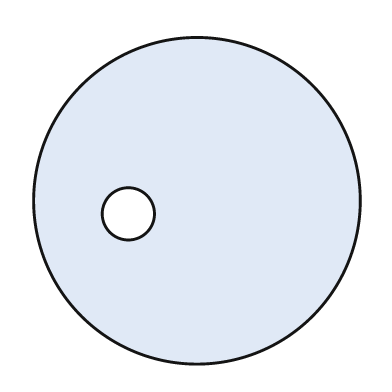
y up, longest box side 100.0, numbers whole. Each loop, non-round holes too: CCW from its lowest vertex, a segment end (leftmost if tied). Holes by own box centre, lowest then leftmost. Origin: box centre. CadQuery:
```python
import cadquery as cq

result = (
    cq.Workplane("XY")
    .moveTo(0.0, 0.0)
    .circle(50.0)
    .moveTo(-21.0, -4.0)
    .circle(8.0)
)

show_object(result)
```